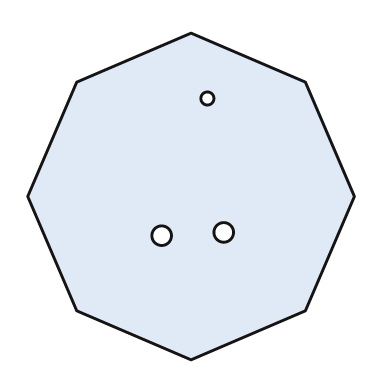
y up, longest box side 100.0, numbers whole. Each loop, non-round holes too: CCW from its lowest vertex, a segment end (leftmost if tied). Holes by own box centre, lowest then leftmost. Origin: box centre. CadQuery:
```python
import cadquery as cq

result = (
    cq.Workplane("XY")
    .moveTo(0.0, -50.0)
    .lineTo(35.0, -35.0)
    .lineTo(50.0, 0.0)
    .lineTo(35.0, 35.0)
    .lineTo(0.0, 50.0)
    .lineTo(-35.0, 35.0)
    .lineTo(-50.0, 0.0)
    .lineTo(-35.0, -35.0)
    .close()
    .moveTo(-9.0, -12.0)
    .circle(3.0)
    .moveTo(10.0, -11.0)
    .circle(3.0)
    .moveTo(5.0, 30.0)
    .circle(2.0)
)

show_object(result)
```